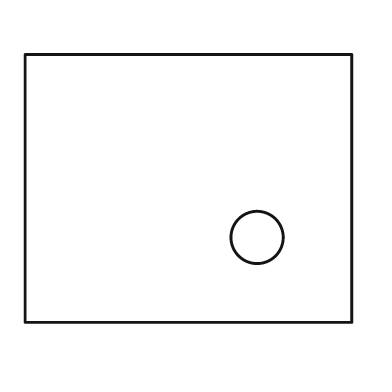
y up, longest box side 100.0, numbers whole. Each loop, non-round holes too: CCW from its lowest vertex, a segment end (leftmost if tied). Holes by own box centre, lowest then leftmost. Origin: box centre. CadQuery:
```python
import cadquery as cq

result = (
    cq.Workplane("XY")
    .moveTo(-50.0, -41.0)
    .lineTo(50.0, -41.0)
    .lineTo(50.0, 41.0)
    .lineTo(-50.0, 41.0)
    .close()
    .moveTo(21.0, -15.0)
    .circle(8.0)
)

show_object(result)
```